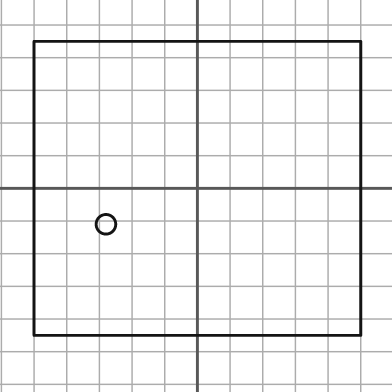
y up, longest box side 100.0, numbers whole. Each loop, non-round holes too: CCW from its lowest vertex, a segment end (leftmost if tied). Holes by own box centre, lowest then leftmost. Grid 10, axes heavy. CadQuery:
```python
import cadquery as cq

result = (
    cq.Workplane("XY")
    .moveTo(-50.0, -45.0)
    .lineTo(50.0, -45.0)
    .lineTo(50.0, 45.0)
    .lineTo(-50.0, 45.0)
    .close()
    .moveTo(-28.0, -11.0)
    .circle(3.0)
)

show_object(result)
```